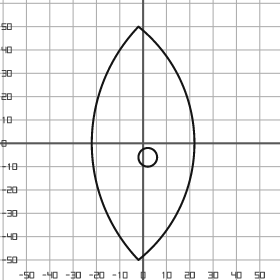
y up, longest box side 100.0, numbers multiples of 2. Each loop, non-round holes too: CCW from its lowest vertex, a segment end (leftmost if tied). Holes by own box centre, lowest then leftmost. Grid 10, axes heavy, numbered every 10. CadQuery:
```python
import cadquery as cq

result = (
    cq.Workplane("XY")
    .moveTo(-2.0, -50.0)
    .threePointArc((22.0, 0.0), (-2.0, 50.0))
    .threePointArc((-22.0, 0.0), (-2.0, -50.0))
    .close()
    .moveTo(2.0, -6.0)
    .circle(4.0)
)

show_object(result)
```